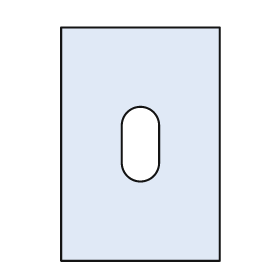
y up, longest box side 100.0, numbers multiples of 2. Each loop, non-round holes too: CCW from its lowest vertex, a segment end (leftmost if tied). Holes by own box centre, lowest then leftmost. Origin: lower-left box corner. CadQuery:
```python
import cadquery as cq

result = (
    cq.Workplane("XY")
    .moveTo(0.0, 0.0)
    .lineTo(68.0, 0.0)
    .lineTo(68.0, 100.0)
    .lineTo(0.0, 100.0)
    .close()
    .moveTo(26.0, 42.0)
    .threePointArc((34.0, 34.0), (42.0, 42.0))
    .lineTo(42.0, 58.0)
    .threePointArc((34.0, 66.0), (26.0, 58.0))
    .close()
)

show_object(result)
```